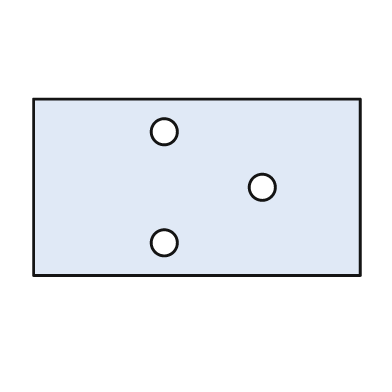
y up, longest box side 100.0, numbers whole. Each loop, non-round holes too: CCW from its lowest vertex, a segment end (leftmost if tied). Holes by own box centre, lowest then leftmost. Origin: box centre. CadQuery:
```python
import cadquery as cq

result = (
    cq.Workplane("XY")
    .moveTo(-50.0, -27.0)
    .lineTo(50.0, -27.0)
    .lineTo(50.0, 27.0)
    .lineTo(-50.0, 27.0)
    .close()
    .moveTo(-10.0, -17.0)
    .circle(4.0)
    .moveTo(20.0, 0.0)
    .circle(4.0)
    .moveTo(-10.0, 17.0)
    .circle(4.0)
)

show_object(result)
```